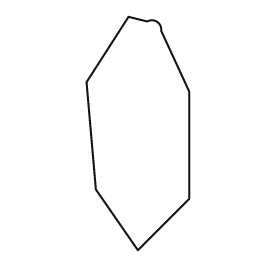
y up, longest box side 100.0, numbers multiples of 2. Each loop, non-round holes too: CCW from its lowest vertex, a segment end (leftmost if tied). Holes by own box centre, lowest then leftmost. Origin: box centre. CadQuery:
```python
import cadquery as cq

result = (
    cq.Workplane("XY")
    .moveTo(0.0, -50.0)
    .lineTo(22.0, -28.0)
    .lineTo(22.0, 18.0)
    .lineTo(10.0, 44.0)
    .threePointArc((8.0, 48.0), (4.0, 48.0))
    .lineTo(-4.0, 50.0)
    .lineTo(-22.0, 22.0)
    .lineTo(-18.0, -24.0)
    .close()
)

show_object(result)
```